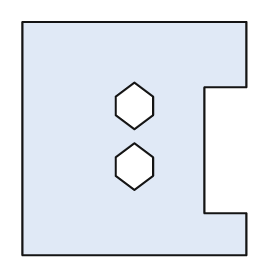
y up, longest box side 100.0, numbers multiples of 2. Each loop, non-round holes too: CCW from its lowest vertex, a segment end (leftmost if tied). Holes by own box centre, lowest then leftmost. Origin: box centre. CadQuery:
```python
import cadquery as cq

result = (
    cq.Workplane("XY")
    .moveTo(-48.0, -50.0)
    .lineTo(48.0, -50.0)
    .lineTo(48.0, -32.0)
    .lineTo(30.0, -32.0)
    .lineTo(30.0, 22.0)
    .lineTo(48.0, 22.0)
    .lineTo(48.0, 50.0)
    .lineTo(-48.0, 50.0)
    .close()
    .moveTo(0.0, -22.0)
    .lineTo(8.0, -16.0)
    .lineTo(8.0, -8.0)
    .lineTo(0.0, -2.0)
    .lineTo(-8.0, -8.0)
    .lineTo(-8.0, -16.0)
    .close()
    .moveTo(0.0, 4.0)
    .lineTo(8.0, 10.0)
    .lineTo(8.0, 18.0)
    .lineTo(0.0, 24.0)
    .lineTo(-8.0, 18.0)
    .lineTo(-8.0, 10.0)
    .close()
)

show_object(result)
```